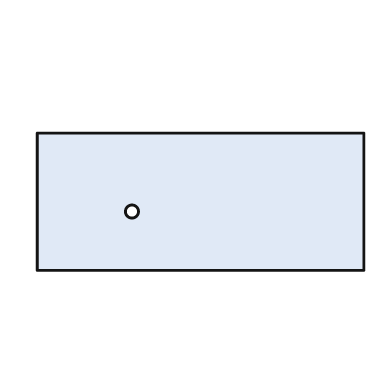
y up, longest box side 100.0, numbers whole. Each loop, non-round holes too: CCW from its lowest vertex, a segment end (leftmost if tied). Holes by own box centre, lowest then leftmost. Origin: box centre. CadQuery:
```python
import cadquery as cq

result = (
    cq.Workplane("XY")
    .moveTo(-50.0, -21.0)
    .lineTo(50.0, -21.0)
    .lineTo(50.0, 21.0)
    .lineTo(-50.0, 21.0)
    .close()
    .moveTo(-21.0, -3.0)
    .circle(2.0)
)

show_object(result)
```